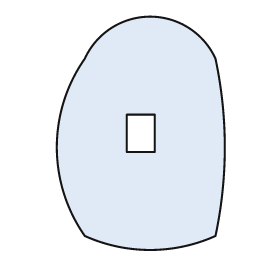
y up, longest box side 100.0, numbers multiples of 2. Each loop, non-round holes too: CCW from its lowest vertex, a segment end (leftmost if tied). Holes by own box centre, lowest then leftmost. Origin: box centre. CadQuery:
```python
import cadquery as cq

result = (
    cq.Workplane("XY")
    .moveTo(-24.0, -44.0)
    .threePointArc((4.0, -50.0), (32.0, -44.0))
    .threePointArc((36.0, -6.0), (32.0, 32.0))
    .threePointArc((4.0, 50.0), (-24.0, 32.0))
    .threePointArc((-36.0, -6.0), (-24.0, -44.0))
    .close()
    .moveTo(-6.0, -8.0)
    .lineTo(6.0, -8.0)
    .lineTo(6.0, 8.0)
    .lineTo(-6.0, 8.0)
    .close()
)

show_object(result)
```